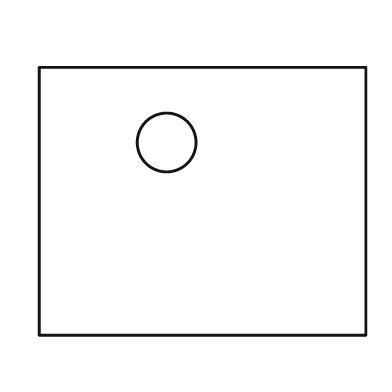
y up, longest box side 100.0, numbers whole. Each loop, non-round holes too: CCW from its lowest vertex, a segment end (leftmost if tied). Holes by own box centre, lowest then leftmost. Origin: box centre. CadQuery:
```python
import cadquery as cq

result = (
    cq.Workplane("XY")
    .moveTo(-50.0, -41.0)
    .lineTo(50.0, -41.0)
    .lineTo(50.0, 41.0)
    .lineTo(-50.0, 41.0)
    .close()
    .moveTo(-11.0, 18.0)
    .circle(9.0)
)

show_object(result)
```